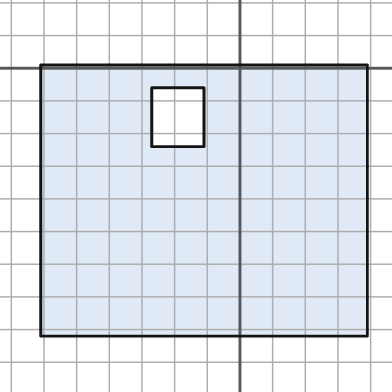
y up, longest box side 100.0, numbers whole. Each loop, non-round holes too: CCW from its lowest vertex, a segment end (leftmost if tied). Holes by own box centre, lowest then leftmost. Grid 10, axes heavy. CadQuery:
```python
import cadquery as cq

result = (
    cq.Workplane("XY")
    .moveTo(-61.0, -82.0)
    .lineTo(39.0, -82.0)
    .lineTo(39.0, 1.0)
    .lineTo(-61.0, 1.0)
    .close()
    .moveTo(-27.0, -24.0)
    .lineTo(-11.0, -24.0)
    .lineTo(-11.0, -6.0)
    .lineTo(-27.0, -6.0)
    .close()
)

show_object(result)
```